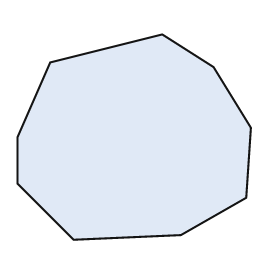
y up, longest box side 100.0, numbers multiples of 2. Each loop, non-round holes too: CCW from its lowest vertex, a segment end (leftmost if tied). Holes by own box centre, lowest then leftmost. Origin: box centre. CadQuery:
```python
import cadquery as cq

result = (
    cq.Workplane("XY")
    .moveTo(-26.0, -44.0)
    .lineTo(20.0, -42.0)
    .lineTo(48.0, -26.0)
    .lineTo(50.0, 4.0)
    .lineTo(34.0, 30.0)
    .lineTo(12.0, 44.0)
    .lineTo(-36.0, 32.0)
    .lineTo(-50.0, 0.0)
    .lineTo(-50.0, -20.0)
    .close()
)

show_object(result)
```